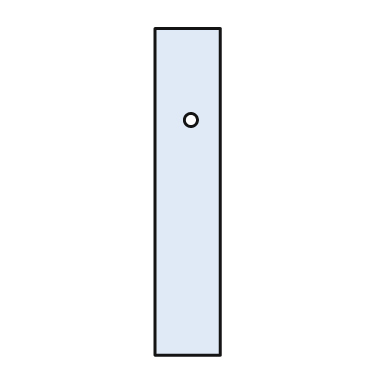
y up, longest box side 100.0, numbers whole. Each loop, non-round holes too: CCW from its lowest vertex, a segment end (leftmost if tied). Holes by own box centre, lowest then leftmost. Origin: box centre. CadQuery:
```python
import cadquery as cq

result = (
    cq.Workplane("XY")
    .moveTo(-10.0, -50.0)
    .lineTo(10.0, -50.0)
    .lineTo(10.0, 50.0)
    .lineTo(-10.0, 50.0)
    .close()
    .moveTo(1.0, 22.0)
    .circle(2.0)
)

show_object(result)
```